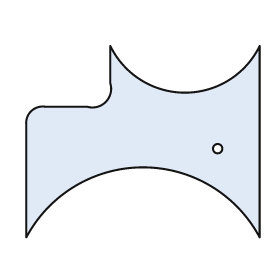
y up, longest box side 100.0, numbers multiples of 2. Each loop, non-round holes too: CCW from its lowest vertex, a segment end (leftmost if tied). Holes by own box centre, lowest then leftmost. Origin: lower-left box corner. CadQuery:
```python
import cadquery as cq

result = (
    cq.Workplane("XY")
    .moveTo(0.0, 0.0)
    .threePointArc((50.0, 30.0), (100.0, 0.0))
    .lineTo(100.0, 82.0)
    .threePointArc((68.0, 62.0), (36.0, 82.0))
    .lineTo(36.0, 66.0)
    .threePointArc((34.0, 58.0), (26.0, 56.0))
    .lineTo(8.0, 56.0)
    .threePointArc((2.0, 54.0), (0.0, 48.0))
    .close()
    .moveTo(82.0, 38.0)
    .circle(2.0)
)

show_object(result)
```